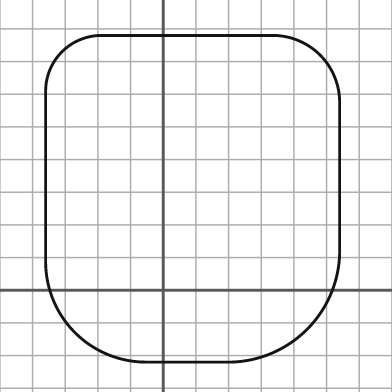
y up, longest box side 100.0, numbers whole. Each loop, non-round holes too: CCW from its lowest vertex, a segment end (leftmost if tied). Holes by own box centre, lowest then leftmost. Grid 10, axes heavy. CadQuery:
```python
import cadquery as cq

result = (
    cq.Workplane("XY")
    .moveTo(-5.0, -22.0)
    .lineTo(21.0, -22.0)
    .threePointArc((44.0, -12.0), (54.0, 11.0))
    .lineTo(54.0, 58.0)
    .threePointArc((48.0, 72.0), (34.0, 78.0))
    .lineTo(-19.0, 78.0)
    .threePointArc((-31.0, 73.0), (-36.0, 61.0))
    .lineTo(-36.0, 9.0)
    .threePointArc((-27.0, -13.0), (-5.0, -22.0))
    .close()
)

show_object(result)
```